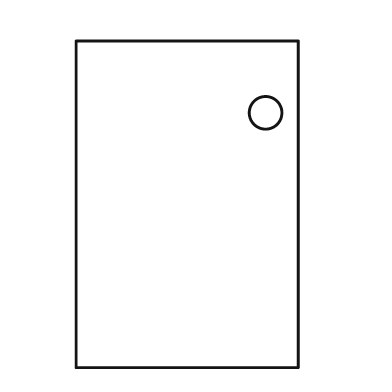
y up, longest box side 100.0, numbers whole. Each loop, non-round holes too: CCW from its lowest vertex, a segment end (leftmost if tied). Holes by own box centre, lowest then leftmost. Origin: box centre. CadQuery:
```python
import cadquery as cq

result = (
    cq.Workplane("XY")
    .moveTo(-34.0, -50.0)
    .lineTo(34.0, -50.0)
    .lineTo(34.0, 50.0)
    .lineTo(-34.0, 50.0)
    .close()
    .moveTo(24.0, 28.0)
    .circle(5.0)
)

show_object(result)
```